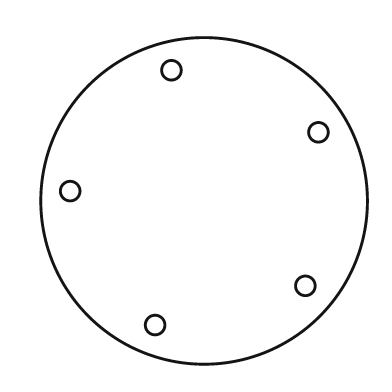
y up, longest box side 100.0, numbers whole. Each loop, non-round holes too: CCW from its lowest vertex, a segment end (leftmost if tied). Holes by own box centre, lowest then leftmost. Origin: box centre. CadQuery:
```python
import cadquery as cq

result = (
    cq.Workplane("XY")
    .moveTo(0.0, 0.0)
    .circle(50.0)
    .moveTo(-15.0, -38.0)
    .circle(3.0)
    .moveTo(31.0, -26.0)
    .circle(3.0)
    .moveTo(-41.0, 3.0)
    .circle(3.0)
    .moveTo(35.0, 21.0)
    .circle(3.0)
    .moveTo(-10.0, 40.0)
    .circle(3.0)
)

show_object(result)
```